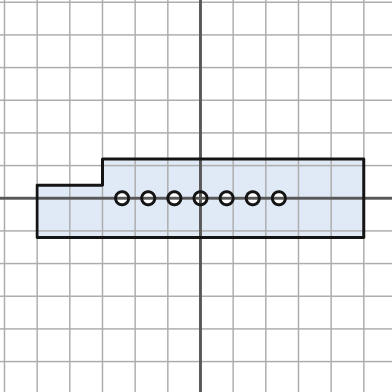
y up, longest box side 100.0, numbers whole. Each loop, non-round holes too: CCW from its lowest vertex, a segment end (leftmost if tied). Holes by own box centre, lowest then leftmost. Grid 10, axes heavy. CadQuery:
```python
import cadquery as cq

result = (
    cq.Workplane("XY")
    .moveTo(-50.0, -12.0)
    .lineTo(50.0, -12.0)
    .lineTo(50.0, 12.0)
    .lineTo(-30.0, 12.0)
    .lineTo(-30.0, 4.0)
    .lineTo(-50.0, 4.0)
    .close()
    .moveTo(-24.0, 0.0)
    .circle(2.0)
    .moveTo(-16.0, 0.0)
    .circle(2.0)
    .moveTo(-8.0, 0.0)
    .circle(2.0)
    .moveTo(0.0, 0.0)
    .circle(2.0)
    .moveTo(8.0, 0.0)
    .circle(2.0)
    .moveTo(16.0, 0.0)
    .circle(2.0)
    .moveTo(24.0, 0.0)
    .circle(2.0)
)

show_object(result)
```